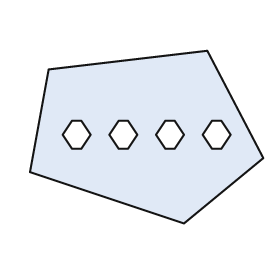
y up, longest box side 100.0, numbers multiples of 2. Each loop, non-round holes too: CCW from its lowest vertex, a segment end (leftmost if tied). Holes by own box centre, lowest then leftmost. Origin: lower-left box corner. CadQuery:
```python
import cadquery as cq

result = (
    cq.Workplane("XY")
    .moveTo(66.0, 0.0)
    .lineTo(100.0, 28.0)
    .lineTo(76.0, 74.0)
    .lineTo(8.0, 66.0)
    .lineTo(0.0, 22.0)
    .close()
    .moveTo(18.0, 32.0)
    .lineTo(22.0, 32.0)
    .lineTo(26.0, 38.0)
    .lineTo(22.0, 44.0)
    .lineTo(18.0, 44.0)
    .lineTo(14.0, 38.0)
    .close()
    .moveTo(38.0, 32.0)
    .lineTo(42.0, 32.0)
    .lineTo(46.0, 38.0)
    .lineTo(42.0, 44.0)
    .lineTo(38.0, 44.0)
    .lineTo(34.0, 38.0)
    .close()
    .moveTo(58.0, 32.0)
    .lineTo(62.0, 32.0)
    .lineTo(66.0, 38.0)
    .lineTo(62.0, 44.0)
    .lineTo(58.0, 44.0)
    .lineTo(54.0, 38.0)
    .close()
    .moveTo(78.0, 32.0)
    .lineTo(82.0, 32.0)
    .lineTo(86.0, 38.0)
    .lineTo(82.0, 44.0)
    .lineTo(78.0, 44.0)
    .lineTo(74.0, 38.0)
    .close()
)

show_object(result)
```